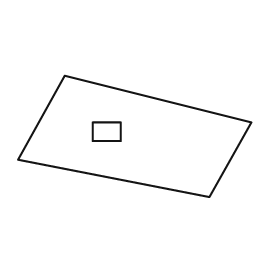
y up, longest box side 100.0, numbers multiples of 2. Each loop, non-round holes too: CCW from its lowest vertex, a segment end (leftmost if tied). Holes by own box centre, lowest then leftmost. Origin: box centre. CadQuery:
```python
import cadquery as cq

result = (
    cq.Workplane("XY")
    .moveTo(32.0, -26.0)
    .lineTo(50.0, 6.0)
    .lineTo(-30.0, 26.0)
    .lineTo(-50.0, -10.0)
    .close()
    .moveTo(-18.0, -2.0)
    .lineTo(-6.0, -2.0)
    .lineTo(-6.0, 6.0)
    .lineTo(-18.0, 6.0)
    .close()
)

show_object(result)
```